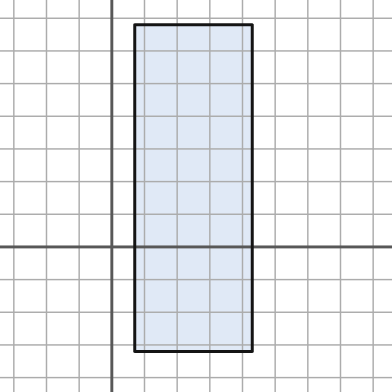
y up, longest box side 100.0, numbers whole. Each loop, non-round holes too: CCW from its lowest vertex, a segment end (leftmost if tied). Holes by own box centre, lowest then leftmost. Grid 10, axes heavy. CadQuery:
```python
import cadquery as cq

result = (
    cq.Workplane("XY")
    .moveTo(7.0, -32.0)
    .lineTo(43.0, -32.0)
    .lineTo(43.0, 68.0)
    .lineTo(7.0, 68.0)
    .close()
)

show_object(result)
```